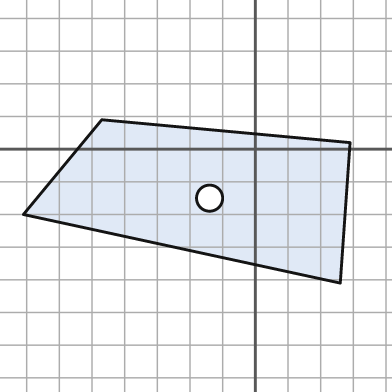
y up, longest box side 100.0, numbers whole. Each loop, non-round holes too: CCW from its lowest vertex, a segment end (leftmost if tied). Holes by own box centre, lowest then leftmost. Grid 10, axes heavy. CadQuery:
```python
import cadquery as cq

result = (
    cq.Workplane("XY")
    .moveTo(26.0, -41.0)
    .lineTo(29.0, 2.0)
    .lineTo(-47.0, 9.0)
    .lineTo(-71.0, -20.0)
    .close()
    .moveTo(-14.0, -15.0)
    .circle(4.0)
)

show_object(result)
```